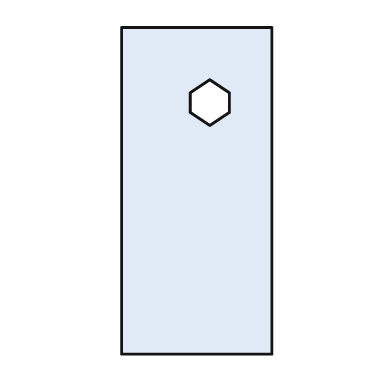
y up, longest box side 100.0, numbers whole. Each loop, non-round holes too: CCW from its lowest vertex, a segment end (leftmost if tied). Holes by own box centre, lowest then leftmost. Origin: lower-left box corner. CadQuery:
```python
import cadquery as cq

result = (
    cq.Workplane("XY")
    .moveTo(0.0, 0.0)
    .lineTo(46.0, 0.0)
    .lineTo(46.0, 100.0)
    .lineTo(0.0, 100.0)
    .close()
    .moveTo(27.0, 70.0)
    .lineTo(33.0, 74.0)
    .lineTo(33.0, 80.0)
    .lineTo(27.0, 84.0)
    .lineTo(21.0, 80.0)
    .lineTo(21.0, 74.0)
    .close()
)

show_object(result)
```